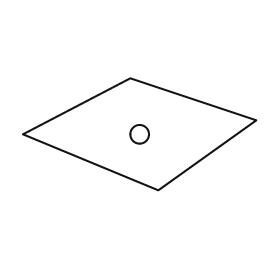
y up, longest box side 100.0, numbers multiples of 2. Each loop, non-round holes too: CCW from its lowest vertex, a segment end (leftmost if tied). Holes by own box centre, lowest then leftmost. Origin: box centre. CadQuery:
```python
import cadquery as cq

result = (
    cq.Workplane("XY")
    .moveTo(8.0, -24.0)
    .lineTo(50.0, 6.0)
    .lineTo(-4.0, 24.0)
    .lineTo(-50.0, 0.0)
    .close()
    .moveTo(0.0, 0.0)
    .circle(4.0)
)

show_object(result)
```